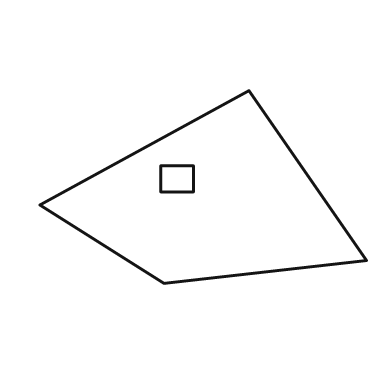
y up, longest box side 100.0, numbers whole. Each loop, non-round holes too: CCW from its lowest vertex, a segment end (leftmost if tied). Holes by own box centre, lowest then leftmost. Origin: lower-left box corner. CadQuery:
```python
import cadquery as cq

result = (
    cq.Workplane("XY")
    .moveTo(38.0, 0.0)
    .lineTo(100.0, 7.0)
    .lineTo(64.0, 59.0)
    .lineTo(0.0, 24.0)
    .close()
    .moveTo(37.0, 28.0)
    .lineTo(47.0, 28.0)
    .lineTo(47.0, 36.0)
    .lineTo(37.0, 36.0)
    .close()
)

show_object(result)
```